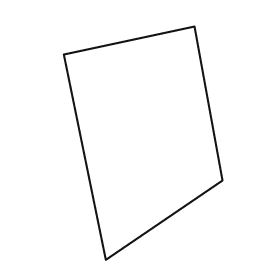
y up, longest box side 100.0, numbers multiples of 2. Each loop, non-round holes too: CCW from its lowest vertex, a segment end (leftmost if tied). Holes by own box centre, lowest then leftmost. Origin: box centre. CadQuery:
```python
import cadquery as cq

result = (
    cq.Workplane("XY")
    .moveTo(-16.0, -50.0)
    .lineTo(34.0, -16.0)
    .lineTo(22.0, 50.0)
    .lineTo(-34.0, 38.0)
    .close()
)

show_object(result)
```